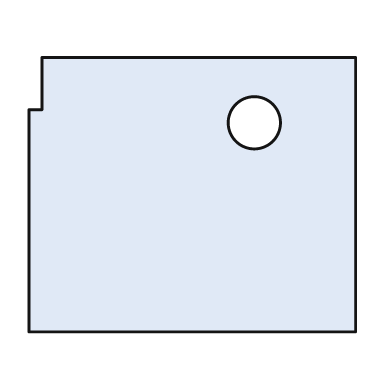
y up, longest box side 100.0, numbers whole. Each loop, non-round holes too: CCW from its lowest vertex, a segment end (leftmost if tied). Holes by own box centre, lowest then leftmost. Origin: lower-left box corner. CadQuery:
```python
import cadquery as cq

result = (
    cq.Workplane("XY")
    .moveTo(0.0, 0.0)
    .lineTo(100.0, 0.0)
    .lineTo(100.0, 84.0)
    .lineTo(4.0, 84.0)
    .lineTo(4.0, 68.0)
    .lineTo(0.0, 68.0)
    .close()
    .moveTo(69.0, 64.0)
    .circle(8.0)
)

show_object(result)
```